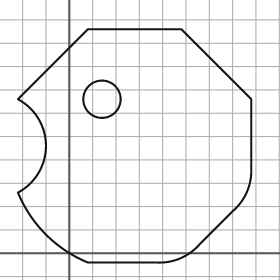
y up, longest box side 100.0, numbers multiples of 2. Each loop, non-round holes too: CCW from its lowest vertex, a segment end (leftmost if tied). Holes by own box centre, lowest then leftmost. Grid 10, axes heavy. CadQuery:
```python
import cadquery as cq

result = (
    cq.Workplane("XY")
    .moveTo(8.0, -4.0)
    .lineTo(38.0, -4.0)
    .threePointArc((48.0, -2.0), (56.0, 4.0))
    .lineTo(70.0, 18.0)
    .threePointArc((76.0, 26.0), (78.0, 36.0))
    .lineTo(78.0, 66.0)
    .lineTo(48.0, 96.0)
    .lineTo(8.0, 96.0)
    .lineTo(-22.0, 66.0)
    .threePointArc((-10.0, 46.0), (-22.0, 26.0))
    .threePointArc((-10.0, 8.0), (8.0, -4.0))
    .close()
    .moveTo(14.0, 66.0)
    .circle(8.0)
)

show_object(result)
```